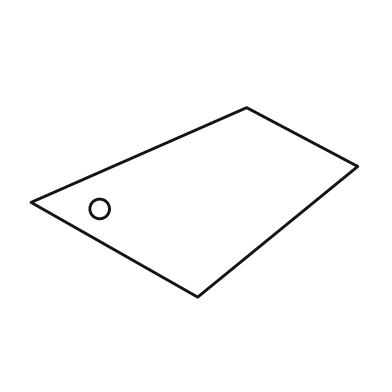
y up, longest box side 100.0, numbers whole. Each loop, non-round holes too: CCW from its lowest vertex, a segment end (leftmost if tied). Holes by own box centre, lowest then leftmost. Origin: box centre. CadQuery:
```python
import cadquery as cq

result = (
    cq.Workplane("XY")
    .moveTo(1.0, -29.0)
    .lineTo(50.0, 11.0)
    .lineTo(16.0, 29.0)
    .lineTo(-50.0, 0.0)
    .close()
    .moveTo(-29.0, -2.0)
    .circle(3.0)
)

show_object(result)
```